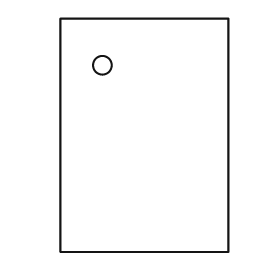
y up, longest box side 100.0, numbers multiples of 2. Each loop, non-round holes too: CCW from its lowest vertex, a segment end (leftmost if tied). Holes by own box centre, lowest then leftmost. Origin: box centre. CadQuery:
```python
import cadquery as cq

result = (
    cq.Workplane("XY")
    .moveTo(-36.0, -50.0)
    .lineTo(36.0, -50.0)
    .lineTo(36.0, 50.0)
    .lineTo(-36.0, 50.0)
    .close()
    .moveTo(-18.0, 30.0)
    .circle(4.0)
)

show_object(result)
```